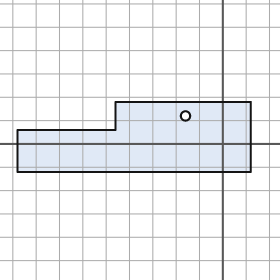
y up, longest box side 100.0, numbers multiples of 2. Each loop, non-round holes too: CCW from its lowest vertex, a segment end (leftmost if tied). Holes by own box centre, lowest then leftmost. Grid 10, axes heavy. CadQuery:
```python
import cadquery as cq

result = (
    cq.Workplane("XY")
    .moveTo(-88.0, -12.0)
    .lineTo(12.0, -12.0)
    .lineTo(12.0, 18.0)
    .lineTo(-46.0, 18.0)
    .lineTo(-46.0, 6.0)
    .lineTo(-88.0, 6.0)
    .close()
    .moveTo(-16.0, 12.0)
    .circle(2.0)
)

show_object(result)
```